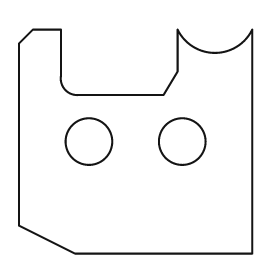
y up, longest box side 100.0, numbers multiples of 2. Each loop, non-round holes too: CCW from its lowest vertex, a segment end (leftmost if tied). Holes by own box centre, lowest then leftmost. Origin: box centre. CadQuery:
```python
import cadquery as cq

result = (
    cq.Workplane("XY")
    .moveTo(-26.0, -48.0)
    .lineTo(50.0, -48.0)
    .lineTo(50.0, 48.0)
    .threePointArc((34.0, 38.0), (18.0, 48.0))
    .lineTo(18.0, 30.0)
    .lineTo(12.0, 20.0)
    .lineTo(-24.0, 20.0)
    .threePointArc((-30.0, 22.0), (-32.0, 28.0))
    .lineTo(-32.0, 48.0)
    .lineTo(-44.0, 48.0)
    .lineTo(-50.0, 42.0)
    .lineTo(-50.0, -36.0)
    .close()
    .moveTo(-20.0, 0.0)
    .circle(10.0)
    .moveTo(20.0, 0.0)
    .circle(10.0)
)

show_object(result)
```